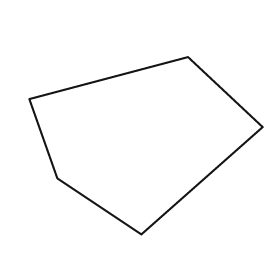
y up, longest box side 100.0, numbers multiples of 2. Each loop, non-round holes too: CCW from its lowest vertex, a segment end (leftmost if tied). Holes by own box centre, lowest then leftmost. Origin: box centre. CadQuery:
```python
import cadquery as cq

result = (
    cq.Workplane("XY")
    .moveTo(-2.0, -38.0)
    .lineTo(50.0, 8.0)
    .lineTo(18.0, 38.0)
    .lineTo(-50.0, 20.0)
    .lineTo(-38.0, -14.0)
    .close()
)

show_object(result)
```